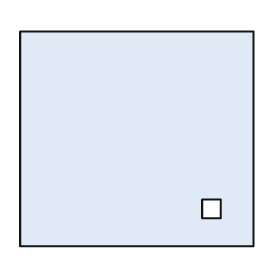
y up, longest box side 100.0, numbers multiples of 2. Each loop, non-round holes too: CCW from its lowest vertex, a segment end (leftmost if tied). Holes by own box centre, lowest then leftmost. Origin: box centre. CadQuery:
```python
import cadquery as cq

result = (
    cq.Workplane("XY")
    .moveTo(-50.0, -46.0)
    .lineTo(50.0, -46.0)
    .lineTo(50.0, 46.0)
    .lineTo(-50.0, 46.0)
    .close()
    .moveTo(28.0, -34.0)
    .lineTo(36.0, -34.0)
    .lineTo(36.0, -26.0)
    .lineTo(28.0, -26.0)
    .close()
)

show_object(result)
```